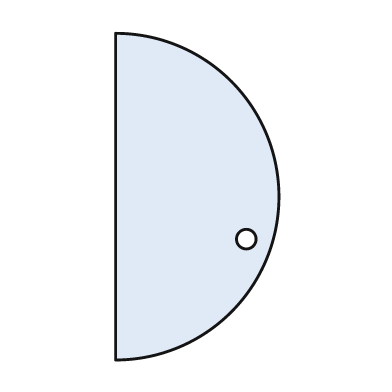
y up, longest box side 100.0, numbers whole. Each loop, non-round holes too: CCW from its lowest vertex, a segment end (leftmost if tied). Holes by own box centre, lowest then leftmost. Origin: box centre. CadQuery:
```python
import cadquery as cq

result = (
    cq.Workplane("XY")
    .moveTo(-25.0, -50.0)
    .threePointArc((25.0, 0.0), (-25.0, 50.0))
    .close()
    .moveTo(15.0, -13.0)
    .circle(3.0)
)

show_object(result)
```